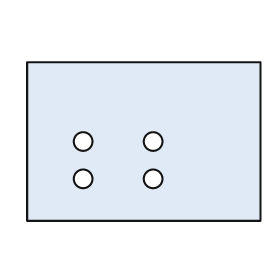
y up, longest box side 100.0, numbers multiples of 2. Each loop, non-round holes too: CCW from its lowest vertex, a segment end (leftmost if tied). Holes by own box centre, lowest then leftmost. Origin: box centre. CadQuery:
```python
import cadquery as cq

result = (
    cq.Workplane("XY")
    .moveTo(-50.0, -34.0)
    .lineTo(50.0, -34.0)
    .lineTo(50.0, 34.0)
    .lineTo(-50.0, 34.0)
    .close()
    .moveTo(-26.0, -16.0)
    .circle(4.0)
    .moveTo(4.0, -16.0)
    .circle(4.0)
    .moveTo(-26.0, 0.0)
    .circle(4.0)
    .moveTo(4.0, 0.0)
    .circle(4.0)
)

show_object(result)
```